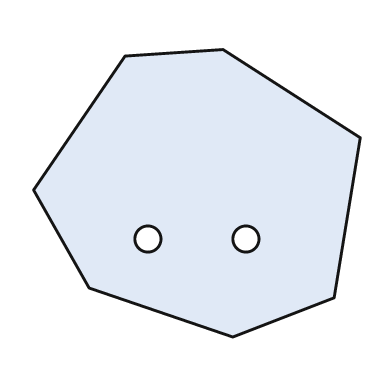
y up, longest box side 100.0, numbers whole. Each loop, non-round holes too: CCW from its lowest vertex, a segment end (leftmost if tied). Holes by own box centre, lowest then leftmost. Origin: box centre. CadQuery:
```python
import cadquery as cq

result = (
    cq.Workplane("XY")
    .moveTo(11.0, -44.0)
    .lineTo(42.0, -32.0)
    .lineTo(50.0, 17.0)
    .lineTo(8.0, 44.0)
    .lineTo(-22.0, 42.0)
    .lineTo(-50.0, 1.0)
    .lineTo(-33.0, -29.0)
    .close()
    .moveTo(-15.0, -14.0)
    .circle(4.0)
    .moveTo(15.0, -14.0)
    .circle(4.0)
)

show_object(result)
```